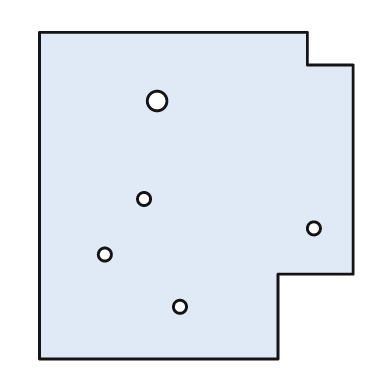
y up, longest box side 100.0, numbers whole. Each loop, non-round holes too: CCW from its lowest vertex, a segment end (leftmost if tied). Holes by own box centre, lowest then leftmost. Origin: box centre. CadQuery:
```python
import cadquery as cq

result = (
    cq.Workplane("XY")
    .moveTo(-48.0, -50.0)
    .lineTo(25.0, -50.0)
    .lineTo(25.0, -24.0)
    .lineTo(48.0, -24.0)
    .lineTo(48.0, 40.0)
    .lineTo(34.0, 40.0)
    .lineTo(34.0, 50.0)
    .lineTo(-48.0, 50.0)
    .close()
    .moveTo(-5.0, -34.0)
    .circle(2.0)
    .moveTo(-28.0, -18.0)
    .circle(2.0)
    .moveTo(36.0, -10.0)
    .circle(2.0)
    .moveTo(-16.0, -1.0)
    .circle(2.0)
    .moveTo(-12.0, 29.0)
    .circle(3.0)
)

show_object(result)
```